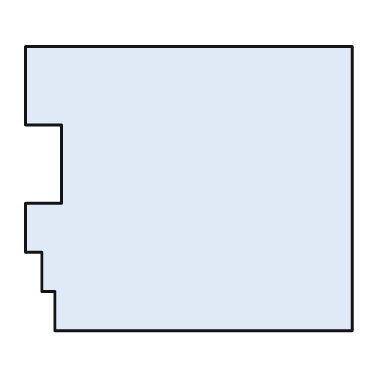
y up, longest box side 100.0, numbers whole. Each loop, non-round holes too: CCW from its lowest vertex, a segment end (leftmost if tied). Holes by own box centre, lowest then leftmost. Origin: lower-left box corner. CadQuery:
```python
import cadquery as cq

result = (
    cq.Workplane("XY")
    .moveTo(9.0, 0.0)
    .lineTo(100.0, 0.0)
    .lineTo(100.0, 87.0)
    .lineTo(0.0, 87.0)
    .lineTo(0.0, 63.0)
    .lineTo(11.0, 63.0)
    .lineTo(11.0, 39.0)
    .lineTo(0.0, 39.0)
    .lineTo(0.0, 24.0)
    .lineTo(5.0, 24.0)
    .lineTo(5.0, 12.0)
    .lineTo(9.0, 12.0)
    .close()
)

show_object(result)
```